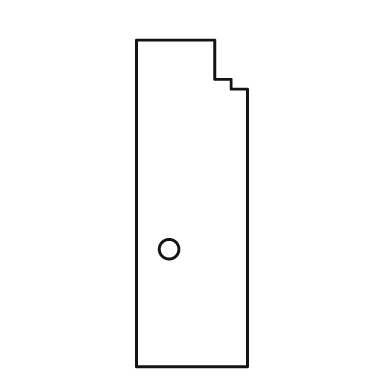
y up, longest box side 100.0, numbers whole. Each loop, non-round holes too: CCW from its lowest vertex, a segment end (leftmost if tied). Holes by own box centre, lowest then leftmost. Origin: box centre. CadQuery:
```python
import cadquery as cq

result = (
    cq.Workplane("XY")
    .moveTo(-17.0, -50.0)
    .lineTo(17.0, -50.0)
    .lineTo(17.0, 35.0)
    .lineTo(12.0, 35.0)
    .lineTo(12.0, 38.0)
    .lineTo(7.0, 38.0)
    .lineTo(7.0, 50.0)
    .lineTo(-17.0, 50.0)
    .close()
    .moveTo(-7.0, -14.0)
    .circle(3.0)
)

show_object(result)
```